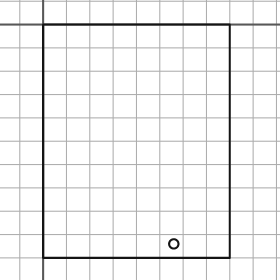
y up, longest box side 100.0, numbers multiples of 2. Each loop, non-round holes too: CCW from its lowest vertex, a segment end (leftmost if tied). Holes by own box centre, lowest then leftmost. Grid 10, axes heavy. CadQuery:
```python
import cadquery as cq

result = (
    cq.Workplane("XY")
    .moveTo(0.0, -100.0)
    .lineTo(80.0, -100.0)
    .lineTo(80.0, 0.0)
    .lineTo(0.0, 0.0)
    .close()
    .moveTo(56.0, -94.0)
    .circle(2.0)
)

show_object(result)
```